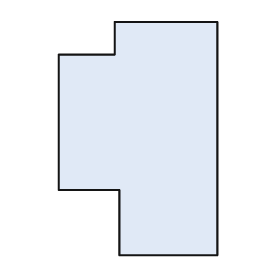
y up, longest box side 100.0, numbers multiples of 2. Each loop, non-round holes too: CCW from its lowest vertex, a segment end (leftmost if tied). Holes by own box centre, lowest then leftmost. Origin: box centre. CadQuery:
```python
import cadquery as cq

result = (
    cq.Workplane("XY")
    .moveTo(-8.0, -50.0)
    .lineTo(34.0, -50.0)
    .lineTo(34.0, 50.0)
    .lineTo(-10.0, 50.0)
    .lineTo(-10.0, 36.0)
    .lineTo(-34.0, 36.0)
    .lineTo(-34.0, -22.0)
    .lineTo(-8.0, -22.0)
    .close()
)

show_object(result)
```